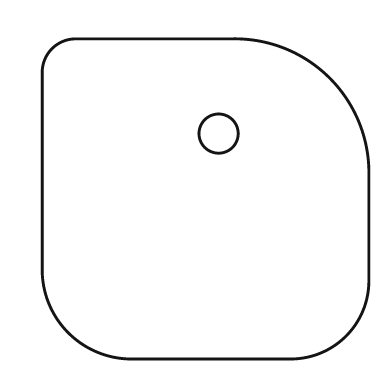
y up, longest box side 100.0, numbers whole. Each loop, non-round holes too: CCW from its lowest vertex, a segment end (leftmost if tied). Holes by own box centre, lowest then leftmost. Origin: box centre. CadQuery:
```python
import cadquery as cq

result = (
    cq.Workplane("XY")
    .moveTo(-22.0, -49.0)
    .lineTo(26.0, -49.0)
    .threePointArc((43.0, -42.0), (50.0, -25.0))
    .lineTo(50.0, 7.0)
    .threePointArc((38.0, 37.0), (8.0, 49.0))
    .lineTo(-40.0, 49.0)
    .threePointArc((-47.0, 46.0), (-50.0, 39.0))
    .lineTo(-50.0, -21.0)
    .threePointArc((-42.0, -41.0), (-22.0, -49.0))
    .close()
    .moveTo(4.0, 20.0)
    .circle(6.0)
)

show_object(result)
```